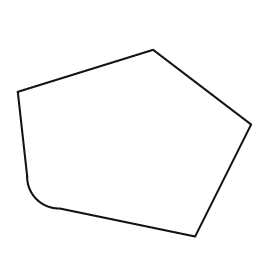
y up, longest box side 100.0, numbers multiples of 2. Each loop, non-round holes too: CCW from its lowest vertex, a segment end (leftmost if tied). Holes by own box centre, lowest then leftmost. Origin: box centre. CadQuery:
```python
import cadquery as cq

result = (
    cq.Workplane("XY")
    .moveTo(26.0, -40.0)
    .lineTo(50.0, 8.0)
    .lineTo(8.0, 40.0)
    .lineTo(-50.0, 22.0)
    .lineTo(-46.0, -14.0)
    .threePointArc((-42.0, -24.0), (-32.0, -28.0))
    .close()
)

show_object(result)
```